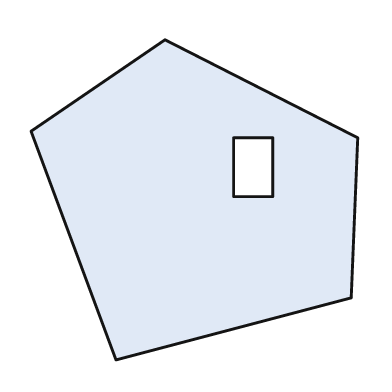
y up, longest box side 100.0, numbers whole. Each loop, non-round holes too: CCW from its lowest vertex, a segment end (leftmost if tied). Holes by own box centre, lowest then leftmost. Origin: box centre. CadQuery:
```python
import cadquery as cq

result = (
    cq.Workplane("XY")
    .moveTo(-24.0, -49.0)
    .lineTo(48.0, -30.0)
    .lineTo(50.0, 19.0)
    .lineTo(-9.0, 49.0)
    .lineTo(-50.0, 21.0)
    .close()
    .moveTo(12.0, 1.0)
    .lineTo(24.0, 1.0)
    .lineTo(24.0, 19.0)
    .lineTo(12.0, 19.0)
    .close()
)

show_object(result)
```